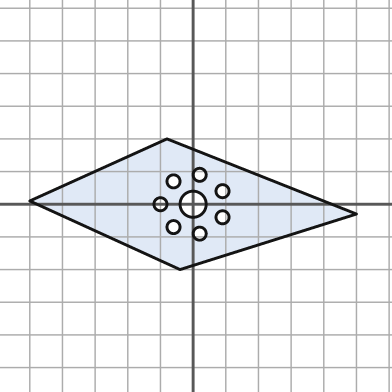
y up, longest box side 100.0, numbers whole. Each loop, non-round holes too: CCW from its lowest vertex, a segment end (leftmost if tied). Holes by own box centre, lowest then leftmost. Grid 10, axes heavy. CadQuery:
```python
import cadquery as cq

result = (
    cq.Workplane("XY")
    .moveTo(-4.0, -20.0)
    .lineTo(50.0, -3.0)
    .lineTo(-8.0, 20.0)
    .lineTo(-50.0, 1.0)
    .close()
    .moveTo(2.0, -9.0)
    .circle(2.0)
    .moveTo(-6.0, -7.0)
    .circle(2.0)
    .moveTo(9.0, -4.0)
    .circle(2.0)
    .moveTo(-10.0, 0.0)
    .circle(2.0)
    .moveTo(0.0, 0.0)
    .circle(4.0)
    .moveTo(9.0, 4.0)
    .circle(2.0)
    .moveTo(-6.0, 7.0)
    .circle(2.0)
    .moveTo(2.0, 9.0)
    .circle(2.0)
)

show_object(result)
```